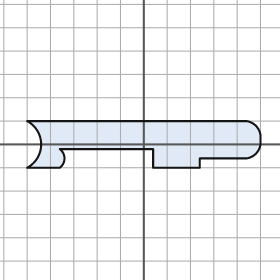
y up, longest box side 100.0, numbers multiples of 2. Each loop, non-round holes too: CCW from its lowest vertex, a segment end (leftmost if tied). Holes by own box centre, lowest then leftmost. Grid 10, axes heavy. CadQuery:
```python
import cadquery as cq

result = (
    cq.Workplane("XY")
    .moveTo(-50.0, -10.0)
    .lineTo(-36.0, -10.0)
    .threePointArc((-34.0, -6.0), (-36.0, -2.0))
    .lineTo(4.0, -2.0)
    .lineTo(4.0, -10.0)
    .lineTo(24.0, -10.0)
    .lineTo(24.0, -6.0)
    .lineTo(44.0, -6.0)
    .threePointArc((48.0, -4.0), (50.0, 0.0))
    .lineTo(50.0, 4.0)
    .threePointArc((48.0, 8.0), (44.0, 10.0))
    .lineTo(-50.0, 10.0)
    .threePointArc((-44.0, 0.0), (-50.0, -10.0))
    .close()
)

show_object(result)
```